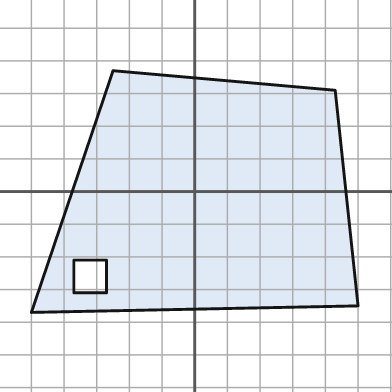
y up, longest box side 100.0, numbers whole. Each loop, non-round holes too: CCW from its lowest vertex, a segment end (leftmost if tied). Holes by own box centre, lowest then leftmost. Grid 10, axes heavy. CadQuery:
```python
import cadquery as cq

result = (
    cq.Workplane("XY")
    .moveTo(-50.0, -37.0)
    .lineTo(50.0, -35.0)
    .lineTo(43.0, 31.0)
    .lineTo(-25.0, 37.0)
    .close()
    .moveTo(-37.0, -31.0)
    .lineTo(-27.0, -31.0)
    .lineTo(-27.0, -21.0)
    .lineTo(-37.0, -21.0)
    .close()
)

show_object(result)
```